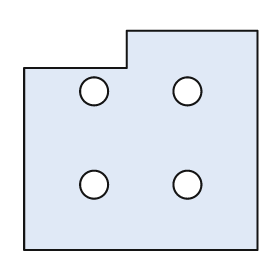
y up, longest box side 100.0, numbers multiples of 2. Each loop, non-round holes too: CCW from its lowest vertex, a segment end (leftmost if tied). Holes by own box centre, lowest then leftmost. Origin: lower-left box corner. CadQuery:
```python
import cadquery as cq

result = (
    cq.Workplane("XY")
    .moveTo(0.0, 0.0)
    .lineTo(100.0, 0.0)
    .lineTo(100.0, 94.0)
    .lineTo(44.0, 94.0)
    .lineTo(44.0, 78.0)
    .lineTo(0.0, 78.0)
    .close()
    .moveTo(30.0, 28.0)
    .circle(6.0)
    .moveTo(70.0, 28.0)
    .circle(6.0)
    .moveTo(30.0, 68.0)
    .circle(6.0)
    .moveTo(70.0, 68.0)
    .circle(6.0)
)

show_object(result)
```